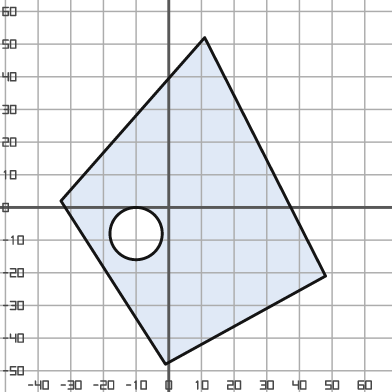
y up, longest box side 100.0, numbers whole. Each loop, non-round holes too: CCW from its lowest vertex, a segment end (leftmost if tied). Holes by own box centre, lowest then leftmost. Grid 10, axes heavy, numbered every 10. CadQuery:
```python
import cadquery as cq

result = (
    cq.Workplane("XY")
    .moveTo(-1.0, -48.0)
    .lineTo(48.0, -21.0)
    .lineTo(11.0, 52.0)
    .lineTo(-33.0, 2.0)
    .close()
    .moveTo(-10.0, -8.0)
    .circle(8.0)
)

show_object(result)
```